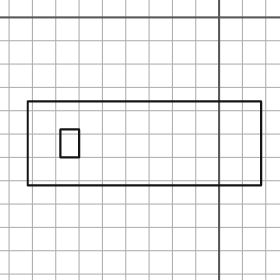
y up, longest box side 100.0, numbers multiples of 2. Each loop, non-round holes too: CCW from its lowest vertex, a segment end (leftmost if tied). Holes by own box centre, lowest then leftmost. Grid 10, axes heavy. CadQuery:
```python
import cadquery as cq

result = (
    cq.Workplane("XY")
    .moveTo(-82.0, -72.0)
    .lineTo(18.0, -72.0)
    .lineTo(18.0, -36.0)
    .lineTo(-82.0, -36.0)
    .close()
    .moveTo(-68.0, -60.0)
    .lineTo(-60.0, -60.0)
    .lineTo(-60.0, -48.0)
    .lineTo(-68.0, -48.0)
    .close()
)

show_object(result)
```